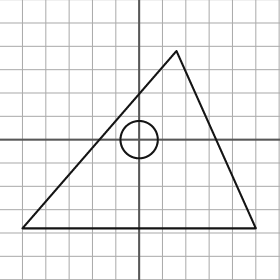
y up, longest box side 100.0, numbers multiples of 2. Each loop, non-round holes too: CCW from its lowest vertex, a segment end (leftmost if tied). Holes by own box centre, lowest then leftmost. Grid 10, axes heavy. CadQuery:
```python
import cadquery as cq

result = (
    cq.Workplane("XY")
    .moveTo(-50.0, -38.0)
    .lineTo(50.0, -38.0)
    .lineTo(16.0, 38.0)
    .close()
    .moveTo(0.0, 0.0)
    .circle(8.0)
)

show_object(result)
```